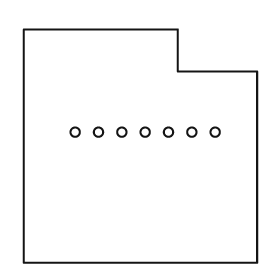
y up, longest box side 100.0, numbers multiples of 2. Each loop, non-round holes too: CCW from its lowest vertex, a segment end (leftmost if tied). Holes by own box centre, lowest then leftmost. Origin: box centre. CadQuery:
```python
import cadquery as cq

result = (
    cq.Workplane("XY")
    .moveTo(-50.0, -50.0)
    .lineTo(50.0, -50.0)
    .lineTo(50.0, 32.0)
    .lineTo(16.0, 32.0)
    .lineTo(16.0, 50.0)
    .lineTo(-50.0, 50.0)
    .close()
    .moveTo(-28.0, 6.0)
    .circle(2.0)
    .moveTo(-18.0, 6.0)
    .circle(2.0)
    .moveTo(-8.0, 6.0)
    .circle(2.0)
    .moveTo(2.0, 6.0)
    .circle(2.0)
    .moveTo(12.0, 6.0)
    .circle(2.0)
    .moveTo(22.0, 6.0)
    .circle(2.0)
    .moveTo(32.0, 6.0)
    .circle(2.0)
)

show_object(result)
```